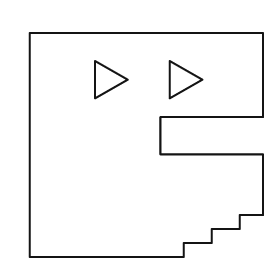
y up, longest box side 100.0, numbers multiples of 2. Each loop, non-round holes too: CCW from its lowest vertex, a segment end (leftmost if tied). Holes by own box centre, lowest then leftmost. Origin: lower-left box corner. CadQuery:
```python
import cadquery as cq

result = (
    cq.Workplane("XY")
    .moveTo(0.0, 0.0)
    .lineTo(66.0, 0.0)
    .lineTo(66.0, 6.0)
    .lineTo(78.0, 6.0)
    .lineTo(78.0, 12.0)
    .lineTo(90.0, 12.0)
    .lineTo(90.0, 18.0)
    .lineTo(100.0, 18.0)
    .lineTo(100.0, 44.0)
    .lineTo(56.0, 44.0)
    .lineTo(56.0, 60.0)
    .lineTo(100.0, 60.0)
    .lineTo(100.0, 96.0)
    .lineTo(0.0, 96.0)
    .close()
    .moveTo(28.0, 68.0)
    .lineTo(42.0, 76.0)
    .lineTo(28.0, 84.0)
    .close()
    .moveTo(60.0, 68.0)
    .lineTo(74.0, 76.0)
    .lineTo(60.0, 84.0)
    .close()
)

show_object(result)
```